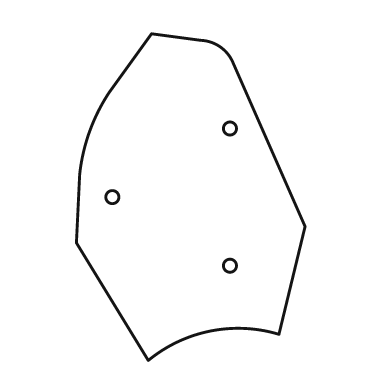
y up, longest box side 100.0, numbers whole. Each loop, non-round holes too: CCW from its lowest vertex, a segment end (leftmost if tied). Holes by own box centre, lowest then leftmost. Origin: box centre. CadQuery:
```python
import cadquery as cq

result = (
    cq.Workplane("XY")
    .moveTo(-13.0, -50.0)
    .threePointArc((6.0, -41.0), (27.0, -42.0))
    .lineTo(35.0, -9.0)
    .lineTo(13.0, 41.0)
    .threePointArc((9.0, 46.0), (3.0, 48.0))
    .lineTo(-12.0, 50.0)
    .lineTo(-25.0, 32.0)
    .threePointArc((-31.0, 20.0), (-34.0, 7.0))
    .lineTo(-35.0, -14.0)
    .close()
    .moveTo(12.0, -21.0)
    .circle(2.0)
    .moveTo(-24.0, 0.0)
    .circle(2.0)
    .moveTo(12.0, 21.0)
    .circle(2.0)
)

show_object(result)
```